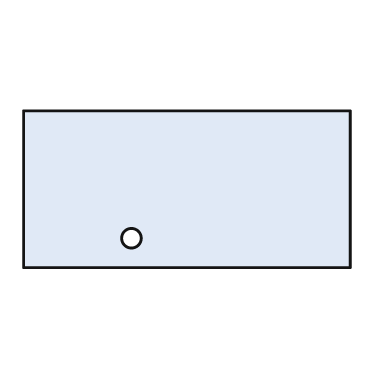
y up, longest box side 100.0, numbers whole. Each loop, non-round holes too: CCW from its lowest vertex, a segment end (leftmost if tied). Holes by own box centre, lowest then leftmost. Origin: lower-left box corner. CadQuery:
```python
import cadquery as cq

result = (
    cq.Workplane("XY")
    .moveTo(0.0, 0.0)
    .lineTo(100.0, 0.0)
    .lineTo(100.0, 48.0)
    .lineTo(0.0, 48.0)
    .close()
    .moveTo(33.0, 9.0)
    .circle(3.0)
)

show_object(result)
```